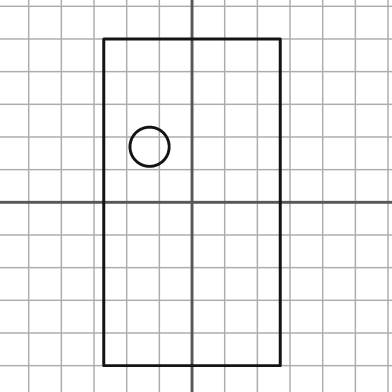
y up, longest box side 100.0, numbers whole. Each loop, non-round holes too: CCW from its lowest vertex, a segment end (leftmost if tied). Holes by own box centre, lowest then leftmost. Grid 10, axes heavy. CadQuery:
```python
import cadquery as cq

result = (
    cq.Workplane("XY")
    .moveTo(-27.0, -50.0)
    .lineTo(27.0, -50.0)
    .lineTo(27.0, 50.0)
    .lineTo(-27.0, 50.0)
    .close()
    .moveTo(-13.0, 17.0)
    .circle(6.0)
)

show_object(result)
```